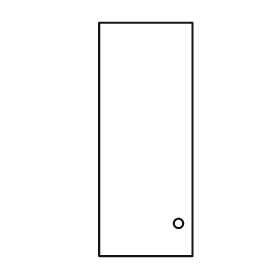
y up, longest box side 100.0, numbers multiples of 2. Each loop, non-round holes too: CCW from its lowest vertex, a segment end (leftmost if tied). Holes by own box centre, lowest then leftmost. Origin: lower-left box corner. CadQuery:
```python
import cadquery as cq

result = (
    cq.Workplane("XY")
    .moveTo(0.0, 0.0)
    .lineTo(40.0, 0.0)
    .lineTo(40.0, 100.0)
    .lineTo(0.0, 100.0)
    .close()
    .moveTo(34.0, 14.0)
    .circle(2.0)
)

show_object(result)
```